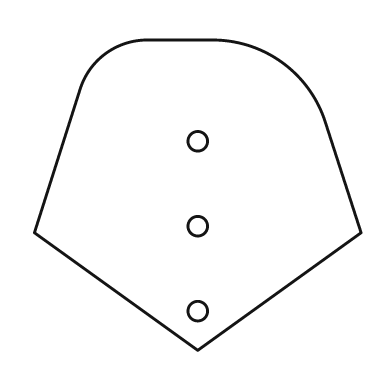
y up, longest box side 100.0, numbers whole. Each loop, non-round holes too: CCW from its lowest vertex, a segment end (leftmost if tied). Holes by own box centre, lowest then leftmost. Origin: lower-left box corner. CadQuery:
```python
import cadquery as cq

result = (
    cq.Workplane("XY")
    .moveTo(50.0, 0.0)
    .lineTo(100.0, 36.0)
    .lineTo(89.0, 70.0)
    .threePointArc((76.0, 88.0), (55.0, 95.0))
    .lineTo(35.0, 95.0)
    .threePointArc((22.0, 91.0), (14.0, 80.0))
    .lineTo(0.0, 36.0)
    .close()
    .moveTo(50.0, 12.0)
    .circle(3.0)
    .moveTo(50.0, 38.0)
    .circle(3.0)
    .moveTo(50.0, 64.0)
    .circle(3.0)
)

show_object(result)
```